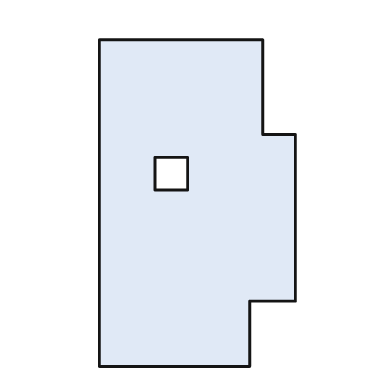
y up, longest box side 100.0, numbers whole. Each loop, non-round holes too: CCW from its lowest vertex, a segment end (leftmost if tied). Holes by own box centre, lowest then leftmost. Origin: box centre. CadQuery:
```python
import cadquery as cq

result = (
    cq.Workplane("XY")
    .moveTo(-30.0, -50.0)
    .lineTo(16.0, -50.0)
    .lineTo(16.0, -30.0)
    .lineTo(30.0, -30.0)
    .lineTo(30.0, 21.0)
    .lineTo(20.0, 21.0)
    .lineTo(20.0, 50.0)
    .lineTo(-30.0, 50.0)
    .close()
    .moveTo(-13.0, 4.0)
    .lineTo(-3.0, 4.0)
    .lineTo(-3.0, 14.0)
    .lineTo(-13.0, 14.0)
    .close()
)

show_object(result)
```